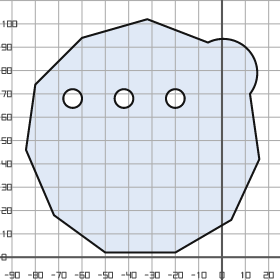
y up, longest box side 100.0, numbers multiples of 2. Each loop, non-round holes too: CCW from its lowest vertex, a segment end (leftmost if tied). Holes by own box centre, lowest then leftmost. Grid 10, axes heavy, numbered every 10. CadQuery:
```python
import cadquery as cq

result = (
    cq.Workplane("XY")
    .moveTo(-50.0, 2.0)
    .lineTo(-20.0, 2.0)
    .lineTo(4.0, 16.0)
    .lineTo(16.0, 42.0)
    .lineTo(12.0, 70.0)
    .threePointArc((12.0, 88.0), (-6.0, 92.0))
    .lineTo(-32.0, 102.0)
    .lineTo(-60.0, 94.0)
    .lineTo(-80.0, 74.0)
    .lineTo(-84.0, 46.0)
    .lineTo(-72.0, 18.0)
    .close()
    .moveTo(-64.0, 68.0)
    .circle(4.0)
    .moveTo(-42.0, 68.0)
    .circle(4.0)
    .moveTo(-20.0, 68.0)
    .circle(4.0)
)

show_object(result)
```